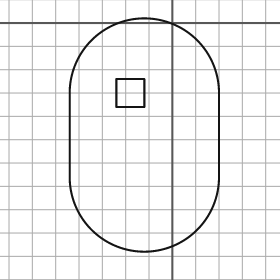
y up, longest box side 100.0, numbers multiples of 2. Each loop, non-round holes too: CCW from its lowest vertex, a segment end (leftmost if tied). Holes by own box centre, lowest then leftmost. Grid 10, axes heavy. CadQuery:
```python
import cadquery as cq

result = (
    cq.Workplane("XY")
    .moveTo(-44.0, -66.0)
    .threePointArc((-12.0, -98.0), (20.0, -66.0))
    .lineTo(20.0, -30.0)
    .threePointArc((-12.0, 2.0), (-44.0, -30.0))
    .close()
    .moveTo(-24.0, -36.0)
    .lineTo(-12.0, -36.0)
    .lineTo(-12.0, -24.0)
    .lineTo(-24.0, -24.0)
    .close()
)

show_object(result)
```